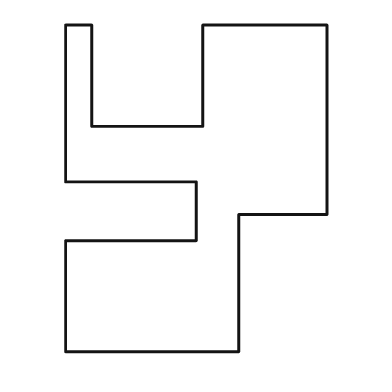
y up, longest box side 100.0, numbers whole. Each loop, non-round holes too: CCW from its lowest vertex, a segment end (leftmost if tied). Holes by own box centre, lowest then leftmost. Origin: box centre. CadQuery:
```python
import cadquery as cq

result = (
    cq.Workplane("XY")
    .moveTo(-40.0, -50.0)
    .lineTo(13.0, -50.0)
    .lineTo(13.0, -8.0)
    .lineTo(40.0, -8.0)
    .lineTo(40.0, 50.0)
    .lineTo(2.0, 50.0)
    .lineTo(2.0, 19.0)
    .lineTo(-32.0, 19.0)
    .lineTo(-32.0, 50.0)
    .lineTo(-40.0, 50.0)
    .lineTo(-40.0, 2.0)
    .lineTo(0.0, 2.0)
    .lineTo(0.0, -16.0)
    .lineTo(-40.0, -16.0)
    .close()
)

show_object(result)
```